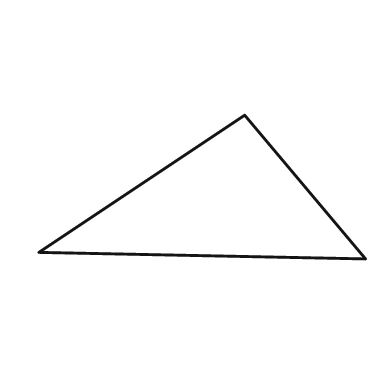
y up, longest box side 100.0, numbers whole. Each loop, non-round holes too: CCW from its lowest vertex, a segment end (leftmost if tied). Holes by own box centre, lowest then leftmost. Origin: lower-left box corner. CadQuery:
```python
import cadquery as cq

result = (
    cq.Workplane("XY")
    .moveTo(100.0, 0.0)
    .lineTo(63.0, 44.0)
    .lineTo(0.0, 2.0)
    .close()
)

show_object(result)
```